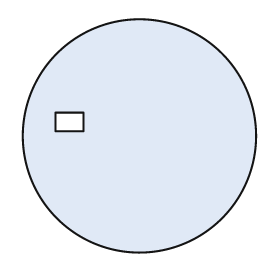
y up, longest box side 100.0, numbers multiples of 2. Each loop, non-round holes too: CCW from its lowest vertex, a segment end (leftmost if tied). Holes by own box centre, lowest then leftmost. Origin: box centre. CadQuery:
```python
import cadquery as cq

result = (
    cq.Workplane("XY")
    .moveTo(0.0, 0.0)
    .circle(50.0)
    .moveTo(-36.0, 2.0)
    .lineTo(-24.0, 2.0)
    .lineTo(-24.0, 10.0)
    .lineTo(-36.0, 10.0)
    .close()
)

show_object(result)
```